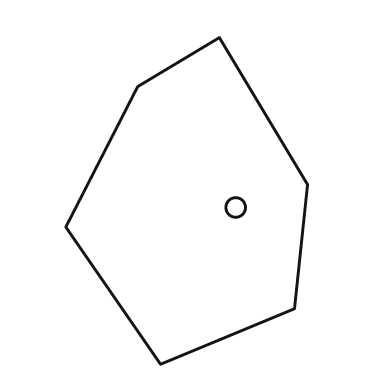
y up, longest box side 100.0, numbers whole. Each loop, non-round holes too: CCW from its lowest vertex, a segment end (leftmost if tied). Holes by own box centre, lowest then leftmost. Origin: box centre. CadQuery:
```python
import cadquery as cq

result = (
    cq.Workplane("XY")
    .moveTo(-8.0, -50.0)
    .lineTo(33.0, -33.0)
    .lineTo(37.0, 5.0)
    .lineTo(10.0, 50.0)
    .lineTo(-15.0, 35.0)
    .lineTo(-37.0, -8.0)
    .close()
    .moveTo(15.0, -2.0)
    .circle(3.0)
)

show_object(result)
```